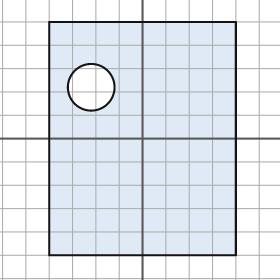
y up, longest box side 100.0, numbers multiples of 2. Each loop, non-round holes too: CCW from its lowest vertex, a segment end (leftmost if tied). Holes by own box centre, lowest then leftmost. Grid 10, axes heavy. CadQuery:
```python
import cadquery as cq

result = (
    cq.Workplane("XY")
    .moveTo(-40.0, -50.0)
    .lineTo(40.0, -50.0)
    .lineTo(40.0, 50.0)
    .lineTo(-40.0, 50.0)
    .close()
    .moveTo(-22.0, 22.0)
    .circle(10.0)
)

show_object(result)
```